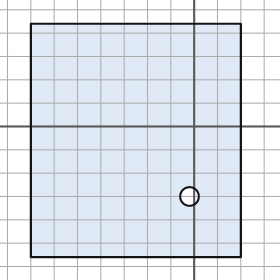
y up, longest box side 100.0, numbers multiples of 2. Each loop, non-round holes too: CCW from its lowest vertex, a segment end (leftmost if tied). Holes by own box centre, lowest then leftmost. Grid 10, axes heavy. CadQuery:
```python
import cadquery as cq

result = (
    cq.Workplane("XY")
    .moveTo(-70.0, -56.0)
    .lineTo(20.0, -56.0)
    .lineTo(20.0, 44.0)
    .lineTo(-70.0, 44.0)
    .close()
    .moveTo(-2.0, -30.0)
    .circle(4.0)
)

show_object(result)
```